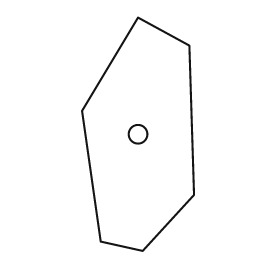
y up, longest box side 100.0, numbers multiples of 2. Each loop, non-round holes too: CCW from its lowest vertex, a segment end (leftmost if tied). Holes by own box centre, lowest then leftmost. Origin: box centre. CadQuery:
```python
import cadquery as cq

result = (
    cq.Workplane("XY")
    .moveTo(2.0, -50.0)
    .lineTo(24.0, -26.0)
    .lineTo(22.0, 38.0)
    .lineTo(0.0, 50.0)
    .lineTo(-24.0, 10.0)
    .lineTo(-16.0, -46.0)
    .close()
    .moveTo(0.0, 0.0)
    .circle(4.0)
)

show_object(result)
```